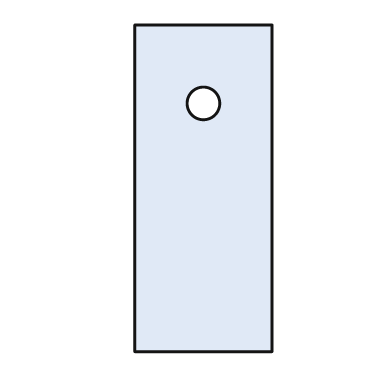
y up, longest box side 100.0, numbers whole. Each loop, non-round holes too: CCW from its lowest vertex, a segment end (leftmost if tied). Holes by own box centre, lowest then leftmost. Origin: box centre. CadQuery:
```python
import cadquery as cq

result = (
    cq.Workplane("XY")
    .moveTo(-21.0, -50.0)
    .lineTo(21.0, -50.0)
    .lineTo(21.0, 50.0)
    .lineTo(-21.0, 50.0)
    .close()
    .moveTo(0.0, 26.0)
    .circle(5.0)
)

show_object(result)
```